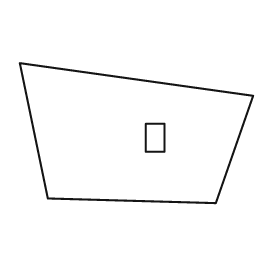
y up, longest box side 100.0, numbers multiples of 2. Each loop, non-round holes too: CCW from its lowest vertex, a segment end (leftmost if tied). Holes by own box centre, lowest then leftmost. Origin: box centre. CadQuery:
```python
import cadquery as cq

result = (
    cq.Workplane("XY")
    .moveTo(34.0, -30.0)
    .lineTo(50.0, 16.0)
    .lineTo(-50.0, 30.0)
    .lineTo(-38.0, -28.0)
    .close()
    .moveTo(4.0, -8.0)
    .lineTo(12.0, -8.0)
    .lineTo(12.0, 4.0)
    .lineTo(4.0, 4.0)
    .close()
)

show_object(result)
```